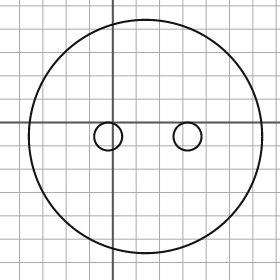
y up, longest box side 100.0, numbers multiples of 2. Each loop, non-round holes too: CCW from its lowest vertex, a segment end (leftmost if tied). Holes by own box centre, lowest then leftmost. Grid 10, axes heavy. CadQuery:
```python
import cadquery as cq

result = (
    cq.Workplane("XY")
    .moveTo(14.0, -6.0)
    .circle(50.0)
    .moveTo(-2.0, -6.0)
    .circle(6.0)
    .moveTo(32.0, -6.0)
    .circle(6.0)
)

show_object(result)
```